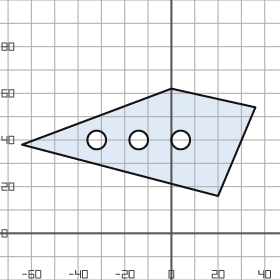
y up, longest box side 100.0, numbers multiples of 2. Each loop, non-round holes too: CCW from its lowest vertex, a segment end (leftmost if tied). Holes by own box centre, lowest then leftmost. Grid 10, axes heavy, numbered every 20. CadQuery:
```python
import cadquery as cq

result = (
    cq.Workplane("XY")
    .moveTo(20.0, 16.0)
    .lineTo(36.0, 54.0)
    .lineTo(0.0, 62.0)
    .lineTo(-64.0, 38.0)
    .close()
    .moveTo(-32.0, 40.0)
    .circle(4.0)
    .moveTo(-14.0, 40.0)
    .circle(4.0)
    .moveTo(4.0, 40.0)
    .circle(4.0)
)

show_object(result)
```